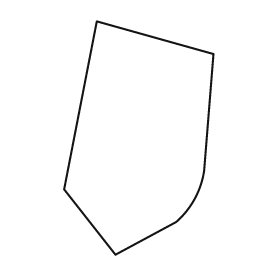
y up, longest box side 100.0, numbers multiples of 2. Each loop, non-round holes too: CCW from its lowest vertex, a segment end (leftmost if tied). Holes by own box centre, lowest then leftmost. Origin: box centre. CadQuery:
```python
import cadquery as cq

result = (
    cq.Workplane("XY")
    .moveTo(-10.0, -50.0)
    .lineTo(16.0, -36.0)
    .threePointArc((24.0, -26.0), (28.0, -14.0))
    .lineTo(32.0, 36.0)
    .lineTo(-18.0, 50.0)
    .lineTo(-32.0, -22.0)
    .close()
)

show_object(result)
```